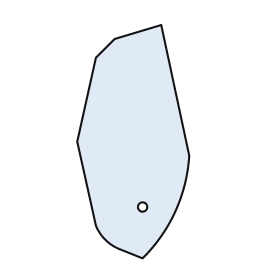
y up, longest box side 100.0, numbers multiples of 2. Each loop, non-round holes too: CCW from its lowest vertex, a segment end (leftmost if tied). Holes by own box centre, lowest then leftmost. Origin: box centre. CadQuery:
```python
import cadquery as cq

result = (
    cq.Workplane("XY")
    .moveTo(4.0, -50.0)
    .threePointArc((18.0, -30.0), (24.0, -6.0))
    .lineTo(12.0, 50.0)
    .lineTo(-8.0, 44.0)
    .lineTo(-16.0, 36.0)
    .lineTo(-24.0, 0.0)
    .lineTo(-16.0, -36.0)
    .threePointArc((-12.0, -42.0), (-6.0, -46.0))
    .close()
    .moveTo(4.0, -28.0)
    .circle(2.0)
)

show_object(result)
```